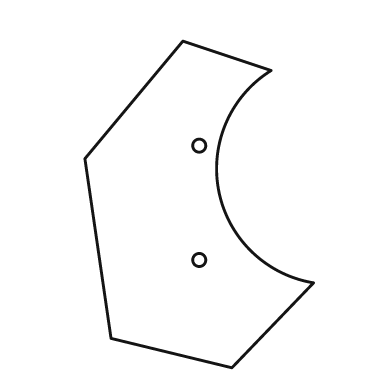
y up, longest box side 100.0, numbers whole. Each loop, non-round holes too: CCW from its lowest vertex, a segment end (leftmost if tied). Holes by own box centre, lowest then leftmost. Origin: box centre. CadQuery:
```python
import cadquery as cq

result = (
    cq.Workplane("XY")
    .moveTo(10.0, -50.0)
    .lineTo(35.0, -24.0)
    .threePointArc((6.0, 4.0), (22.0, 41.0))
    .lineTo(-5.0, 50.0)
    .lineTo(-35.0, 14.0)
    .lineTo(-27.0, -41.0)
    .close()
    .moveTo(0.0, -17.0)
    .circle(2.0)
    .moveTo(0.0, 18.0)
    .circle(2.0)
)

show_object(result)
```